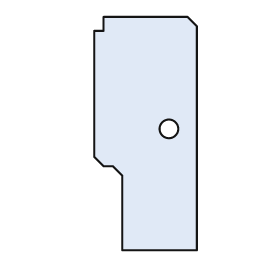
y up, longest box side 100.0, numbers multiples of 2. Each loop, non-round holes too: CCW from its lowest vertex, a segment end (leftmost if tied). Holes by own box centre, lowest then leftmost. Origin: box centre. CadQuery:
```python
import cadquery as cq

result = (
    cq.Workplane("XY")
    .moveTo(-10.0, -50.0)
    .lineTo(22.0, -50.0)
    .lineTo(22.0, 46.0)
    .lineTo(18.0, 50.0)
    .lineTo(-18.0, 50.0)
    .lineTo(-18.0, 44.0)
    .lineTo(-22.0, 44.0)
    .lineTo(-22.0, -10.0)
    .lineTo(-18.0, -14.0)
    .lineTo(-14.0, -14.0)
    .lineTo(-10.0, -18.0)
    .close()
    .moveTo(10.0, 2.0)
    .circle(4.0)
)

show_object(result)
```